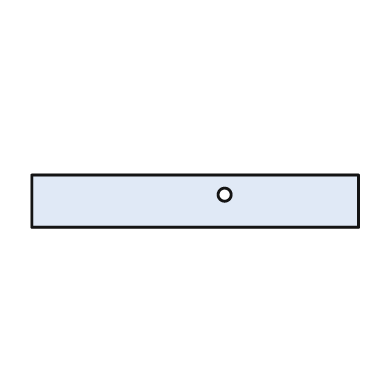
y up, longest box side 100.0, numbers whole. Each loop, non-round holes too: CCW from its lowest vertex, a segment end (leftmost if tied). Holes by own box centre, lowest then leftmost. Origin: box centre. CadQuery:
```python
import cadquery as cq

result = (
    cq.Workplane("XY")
    .moveTo(-50.0, -8.0)
    .lineTo(50.0, -8.0)
    .lineTo(50.0, 8.0)
    .lineTo(-50.0, 8.0)
    .close()
    .moveTo(9.0, 2.0)
    .circle(2.0)
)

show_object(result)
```